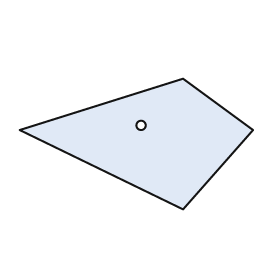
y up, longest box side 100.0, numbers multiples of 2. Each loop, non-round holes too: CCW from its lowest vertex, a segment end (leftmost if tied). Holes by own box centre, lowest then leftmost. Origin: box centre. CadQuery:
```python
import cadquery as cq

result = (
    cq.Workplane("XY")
    .moveTo(20.0, -28.0)
    .lineTo(50.0, 6.0)
    .lineTo(20.0, 28.0)
    .lineTo(-50.0, 6.0)
    .close()
    .moveTo(2.0, 8.0)
    .circle(2.0)
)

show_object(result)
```